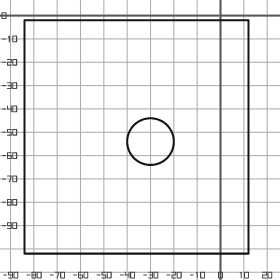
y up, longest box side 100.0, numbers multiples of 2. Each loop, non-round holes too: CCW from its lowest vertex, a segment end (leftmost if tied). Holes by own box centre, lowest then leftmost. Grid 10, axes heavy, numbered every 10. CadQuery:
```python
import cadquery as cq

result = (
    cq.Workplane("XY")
    .moveTo(-84.0, -102.0)
    .lineTo(12.0, -102.0)
    .lineTo(12.0, -2.0)
    .lineTo(-84.0, -2.0)
    .close()
    .moveTo(-30.0, -54.0)
    .circle(10.0)
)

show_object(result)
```